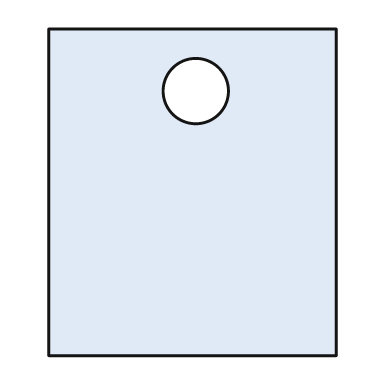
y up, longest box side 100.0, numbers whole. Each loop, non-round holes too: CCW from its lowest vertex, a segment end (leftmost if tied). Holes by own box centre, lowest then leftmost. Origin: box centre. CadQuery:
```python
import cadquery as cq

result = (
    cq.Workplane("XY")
    .moveTo(-44.0, -50.0)
    .lineTo(44.0, -50.0)
    .lineTo(44.0, 50.0)
    .lineTo(-44.0, 50.0)
    .close()
    .moveTo(1.0, 31.0)
    .circle(10.0)
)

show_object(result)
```